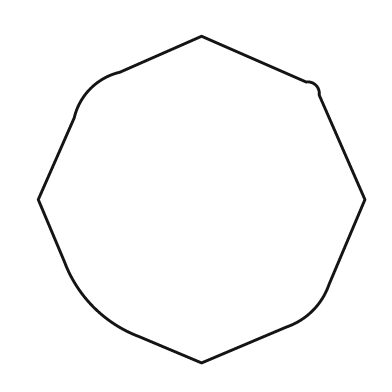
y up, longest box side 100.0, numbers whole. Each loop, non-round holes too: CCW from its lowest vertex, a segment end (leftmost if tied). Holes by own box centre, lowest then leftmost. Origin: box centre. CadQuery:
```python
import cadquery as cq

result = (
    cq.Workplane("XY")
    .moveTo(0.0, -50.0)
    .lineTo(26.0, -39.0)
    .threePointArc((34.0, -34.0), (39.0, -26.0))
    .lineTo(50.0, 0.0)
    .lineTo(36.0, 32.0)
    .threePointArc((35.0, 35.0), (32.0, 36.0))
    .lineTo(0.0, 50.0)
    .lineTo(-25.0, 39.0)
    .threePointArc((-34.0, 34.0), (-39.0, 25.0))
    .lineTo(-50.0, 0.0)
    .lineTo(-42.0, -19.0)
    .threePointArc((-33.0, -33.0), (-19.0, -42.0))
    .close()
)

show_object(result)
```